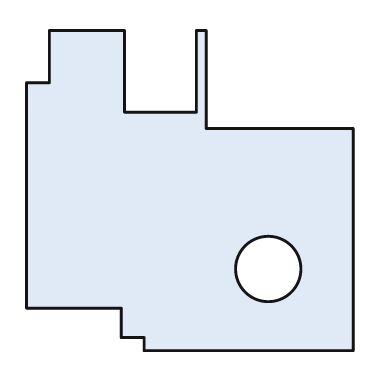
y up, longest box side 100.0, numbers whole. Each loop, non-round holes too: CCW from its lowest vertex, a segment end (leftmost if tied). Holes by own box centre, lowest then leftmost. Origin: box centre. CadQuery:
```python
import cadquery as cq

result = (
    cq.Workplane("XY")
    .moveTo(-14.0, -49.0)
    .lineTo(50.0, -49.0)
    .lineTo(50.0, 19.0)
    .lineTo(5.0, 19.0)
    .lineTo(5.0, 49.0)
    .lineTo(2.0, 49.0)
    .lineTo(2.0, 24.0)
    .lineTo(-20.0, 24.0)
    .lineTo(-20.0, 49.0)
    .lineTo(-43.0, 49.0)
    .lineTo(-43.0, 33.0)
    .lineTo(-50.0, 33.0)
    .lineTo(-50.0, -36.0)
    .lineTo(-21.0, -36.0)
    .lineTo(-21.0, -45.0)
    .lineTo(-14.0, -45.0)
    .close()
    .moveTo(24.0, -24.0)
    .circle(10.0)
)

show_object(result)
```